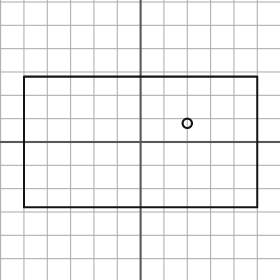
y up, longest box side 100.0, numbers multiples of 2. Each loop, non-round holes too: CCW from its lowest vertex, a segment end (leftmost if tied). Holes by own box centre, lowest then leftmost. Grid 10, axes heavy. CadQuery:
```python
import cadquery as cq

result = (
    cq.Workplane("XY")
    .moveTo(-50.0, -28.0)
    .lineTo(50.0, -28.0)
    .lineTo(50.0, 28.0)
    .lineTo(-50.0, 28.0)
    .close()
    .moveTo(20.0, 8.0)
    .circle(2.0)
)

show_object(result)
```